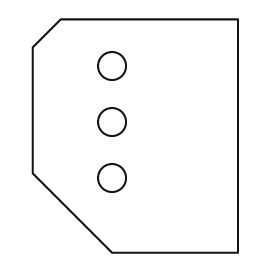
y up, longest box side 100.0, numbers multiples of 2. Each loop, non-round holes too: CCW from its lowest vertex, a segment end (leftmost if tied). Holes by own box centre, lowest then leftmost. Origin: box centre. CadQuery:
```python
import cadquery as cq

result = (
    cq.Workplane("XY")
    .moveTo(-10.0, -50.0)
    .lineTo(44.0, -50.0)
    .lineTo(44.0, 50.0)
    .lineTo(-32.0, 50.0)
    .lineTo(-44.0, 38.0)
    .lineTo(-44.0, -16.0)
    .close()
    .moveTo(-10.0, -18.0)
    .circle(6.0)
    .moveTo(-10.0, 6.0)
    .circle(6.0)
    .moveTo(-10.0, 30.0)
    .circle(6.0)
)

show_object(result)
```